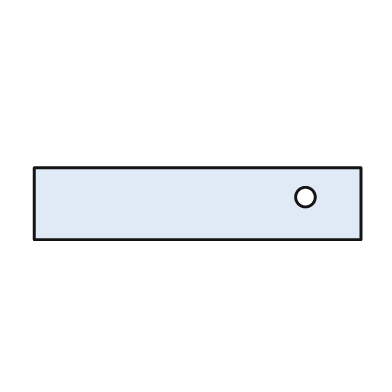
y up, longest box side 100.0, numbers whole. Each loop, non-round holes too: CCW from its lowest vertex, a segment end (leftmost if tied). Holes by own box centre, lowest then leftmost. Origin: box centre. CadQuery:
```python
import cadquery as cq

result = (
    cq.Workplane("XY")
    .moveTo(-50.0, -11.0)
    .lineTo(50.0, -11.0)
    .lineTo(50.0, 11.0)
    .lineTo(-50.0, 11.0)
    .close()
    .moveTo(33.0, 2.0)
    .circle(3.0)
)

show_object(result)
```